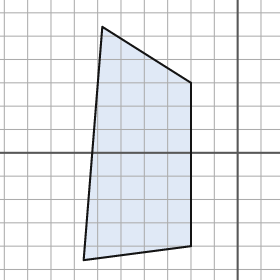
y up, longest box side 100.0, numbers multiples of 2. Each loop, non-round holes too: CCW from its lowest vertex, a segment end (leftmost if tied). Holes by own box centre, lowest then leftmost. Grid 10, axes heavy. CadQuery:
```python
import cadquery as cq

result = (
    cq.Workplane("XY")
    .moveTo(-66.0, -46.0)
    .lineTo(-20.0, -40.0)
    .lineTo(-20.0, 30.0)
    .lineTo(-58.0, 54.0)
    .close()
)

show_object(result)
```